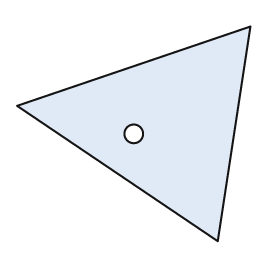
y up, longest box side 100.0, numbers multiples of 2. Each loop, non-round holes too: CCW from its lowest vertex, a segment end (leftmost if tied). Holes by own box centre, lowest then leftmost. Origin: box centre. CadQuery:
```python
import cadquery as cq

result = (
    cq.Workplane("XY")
    .moveTo(36.0, -46.0)
    .lineTo(50.0, 46.0)
    .lineTo(-50.0, 12.0)
    .close()
    .moveTo(0.0, 0.0)
    .circle(4.0)
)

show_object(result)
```